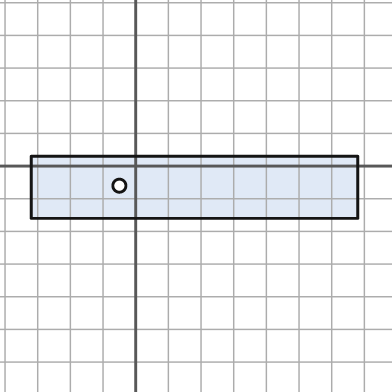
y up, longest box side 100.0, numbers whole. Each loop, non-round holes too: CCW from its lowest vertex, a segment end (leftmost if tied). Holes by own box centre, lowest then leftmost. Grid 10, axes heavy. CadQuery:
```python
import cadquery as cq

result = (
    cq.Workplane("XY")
    .moveTo(-32.0, -16.0)
    .lineTo(68.0, -16.0)
    .lineTo(68.0, 3.0)
    .lineTo(-32.0, 3.0)
    .close()
    .moveTo(-5.0, -6.0)
    .circle(2.0)
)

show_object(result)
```